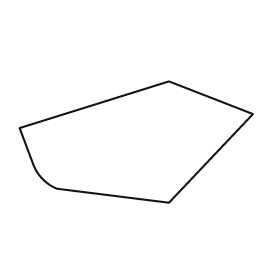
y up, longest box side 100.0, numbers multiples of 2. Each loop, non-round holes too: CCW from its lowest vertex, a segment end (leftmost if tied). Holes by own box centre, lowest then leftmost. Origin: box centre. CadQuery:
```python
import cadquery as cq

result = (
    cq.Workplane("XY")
    .moveTo(14.0, -26.0)
    .lineTo(50.0, 12.0)
    .lineTo(14.0, 26.0)
    .lineTo(-50.0, 6.0)
    .lineTo(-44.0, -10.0)
    .threePointArc((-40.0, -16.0), (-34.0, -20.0))
    .close()
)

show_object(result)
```